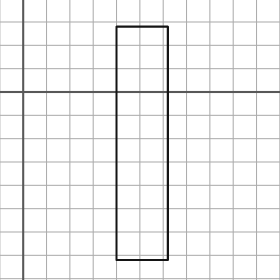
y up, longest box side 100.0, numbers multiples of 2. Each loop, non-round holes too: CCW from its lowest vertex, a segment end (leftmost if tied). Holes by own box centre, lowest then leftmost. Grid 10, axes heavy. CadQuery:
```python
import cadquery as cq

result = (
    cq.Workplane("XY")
    .moveTo(40.0, -72.0)
    .lineTo(62.0, -72.0)
    .lineTo(62.0, 28.0)
    .lineTo(40.0, 28.0)
    .close()
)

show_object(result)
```